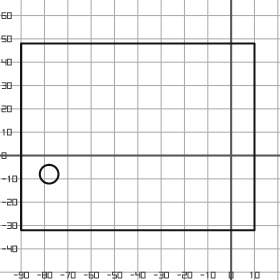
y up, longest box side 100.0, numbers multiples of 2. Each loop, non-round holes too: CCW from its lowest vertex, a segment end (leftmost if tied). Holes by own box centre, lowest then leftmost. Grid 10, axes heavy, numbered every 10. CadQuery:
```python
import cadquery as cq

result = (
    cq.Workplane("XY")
    .moveTo(-90.0, -32.0)
    .lineTo(10.0, -32.0)
    .lineTo(10.0, 48.0)
    .lineTo(-90.0, 48.0)
    .close()
    .moveTo(-78.0, -8.0)
    .circle(4.0)
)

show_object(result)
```